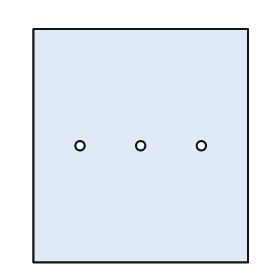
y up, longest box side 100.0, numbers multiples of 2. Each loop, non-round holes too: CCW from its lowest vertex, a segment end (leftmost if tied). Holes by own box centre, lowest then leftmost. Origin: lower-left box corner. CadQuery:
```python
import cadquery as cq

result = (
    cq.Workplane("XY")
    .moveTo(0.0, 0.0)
    .lineTo(92.0, 0.0)
    .lineTo(92.0, 100.0)
    .lineTo(0.0, 100.0)
    .close()
    .moveTo(20.0, 50.0)
    .circle(2.0)
    .moveTo(46.0, 50.0)
    .circle(2.0)
    .moveTo(72.0, 50.0)
    .circle(2.0)
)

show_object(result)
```